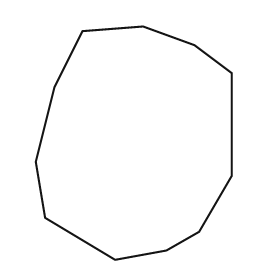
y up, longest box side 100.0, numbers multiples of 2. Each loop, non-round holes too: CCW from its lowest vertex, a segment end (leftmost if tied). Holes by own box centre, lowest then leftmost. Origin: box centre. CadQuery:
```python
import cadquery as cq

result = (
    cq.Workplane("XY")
    .moveTo(-8.0, -50.0)
    .lineTo(14.0, -46.0)
    .lineTo(28.0, -38.0)
    .lineTo(42.0, -14.0)
    .lineTo(42.0, 30.0)
    .lineTo(26.0, 42.0)
    .lineTo(4.0, 50.0)
    .lineTo(-22.0, 48.0)
    .lineTo(-34.0, 24.0)
    .lineTo(-42.0, -8.0)
    .lineTo(-38.0, -32.0)
    .close()
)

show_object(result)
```